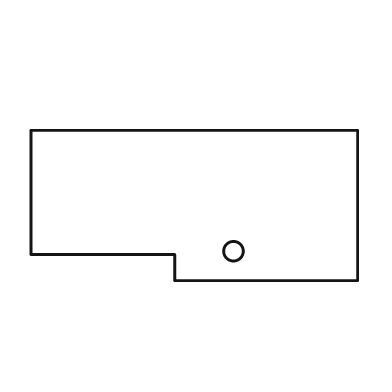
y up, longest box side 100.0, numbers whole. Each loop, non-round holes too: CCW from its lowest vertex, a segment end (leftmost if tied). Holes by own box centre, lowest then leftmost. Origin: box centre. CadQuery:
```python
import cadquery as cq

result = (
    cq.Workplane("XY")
    .moveTo(-6.0, -23.0)
    .lineTo(50.0, -23.0)
    .lineTo(50.0, 23.0)
    .lineTo(-50.0, 23.0)
    .lineTo(-50.0, -15.0)
    .lineTo(-6.0, -15.0)
    .close()
    .moveTo(12.0, -14.0)
    .circle(3.0)
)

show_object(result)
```